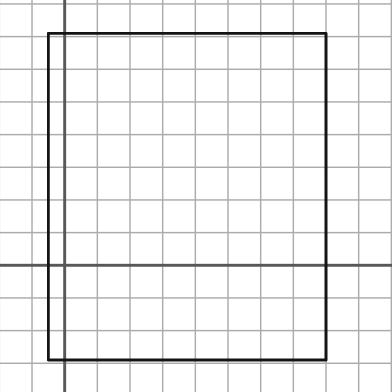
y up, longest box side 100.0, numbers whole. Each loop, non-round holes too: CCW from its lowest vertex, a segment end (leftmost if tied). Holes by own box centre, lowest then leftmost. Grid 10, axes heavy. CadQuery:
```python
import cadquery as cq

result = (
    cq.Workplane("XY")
    .moveTo(-5.0, -29.0)
    .lineTo(80.0, -29.0)
    .lineTo(80.0, 71.0)
    .lineTo(-5.0, 71.0)
    .close()
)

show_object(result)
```